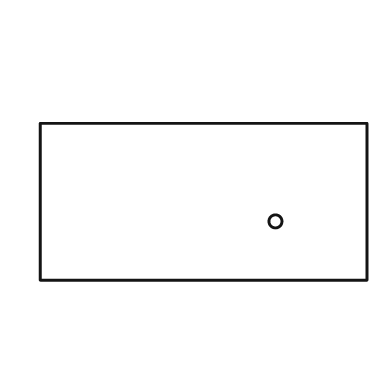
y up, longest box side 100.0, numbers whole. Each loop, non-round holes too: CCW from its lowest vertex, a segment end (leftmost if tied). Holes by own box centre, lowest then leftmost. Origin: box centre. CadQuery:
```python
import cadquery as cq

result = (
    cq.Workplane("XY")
    .moveTo(-50.0, -24.0)
    .lineTo(50.0, -24.0)
    .lineTo(50.0, 24.0)
    .lineTo(-50.0, 24.0)
    .close()
    .moveTo(22.0, -6.0)
    .circle(2.0)
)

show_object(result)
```